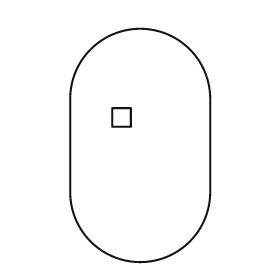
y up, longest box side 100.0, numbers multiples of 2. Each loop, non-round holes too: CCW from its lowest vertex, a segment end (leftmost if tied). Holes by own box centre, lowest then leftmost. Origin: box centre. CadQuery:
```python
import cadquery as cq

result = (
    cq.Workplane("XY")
    .moveTo(-30.0, -20.0)
    .threePointArc((0.0, -50.0), (30.0, -20.0))
    .lineTo(30.0, 20.0)
    .threePointArc((0.0, 50.0), (-30.0, 20.0))
    .close()
    .moveTo(-12.0, 8.0)
    .lineTo(-4.0, 8.0)
    .lineTo(-4.0, 16.0)
    .lineTo(-12.0, 16.0)
    .close()
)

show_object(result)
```